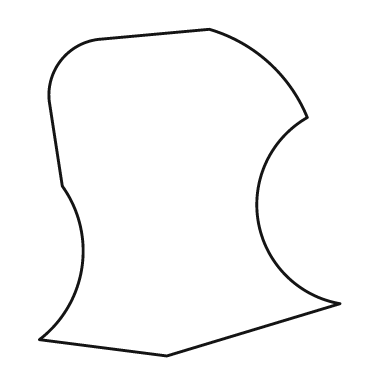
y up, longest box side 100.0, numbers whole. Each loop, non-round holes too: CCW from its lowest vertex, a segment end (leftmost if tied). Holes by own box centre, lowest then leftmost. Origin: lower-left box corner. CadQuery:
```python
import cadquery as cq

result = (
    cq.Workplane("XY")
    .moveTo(39.0, 0.0)
    .lineTo(92.0, 16.0)
    .threePointArc((67.0, 41.0), (82.0, 73.0))
    .threePointArc((70.0, 90.0), (52.0, 100.0))
    .lineTo(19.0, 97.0)
    .threePointArc((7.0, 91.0), (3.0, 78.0))
    .lineTo(7.0, 52.0)
    .threePointArc((13.0, 27.0), (0.0, 5.0))
    .close()
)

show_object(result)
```